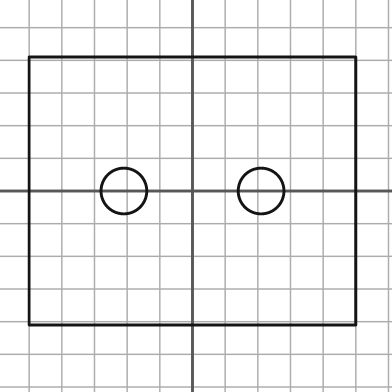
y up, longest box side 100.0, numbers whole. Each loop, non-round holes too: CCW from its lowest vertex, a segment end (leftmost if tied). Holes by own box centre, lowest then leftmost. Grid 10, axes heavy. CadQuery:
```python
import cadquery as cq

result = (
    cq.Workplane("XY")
    .moveTo(-50.0, -41.0)
    .lineTo(50.0, -41.0)
    .lineTo(50.0, 41.0)
    .lineTo(-50.0, 41.0)
    .close()
    .moveTo(-21.0, 0.0)
    .circle(7.0)
    .moveTo(21.0, 0.0)
    .circle(7.0)
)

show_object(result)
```